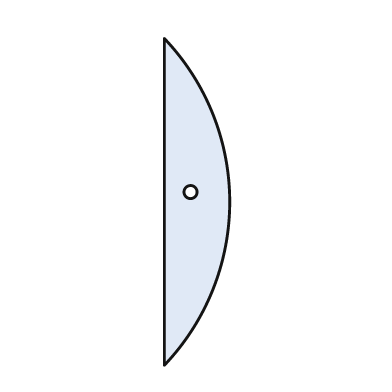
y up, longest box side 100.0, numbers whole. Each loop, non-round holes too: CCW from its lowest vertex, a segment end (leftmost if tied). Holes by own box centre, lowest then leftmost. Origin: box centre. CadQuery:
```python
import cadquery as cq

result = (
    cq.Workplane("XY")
    .moveTo(-10.0, -50.0)
    .threePointArc((10.0, 0.0), (-10.0, 50.0))
    .close()
    .moveTo(-2.0, 3.0)
    .circle(2.0)
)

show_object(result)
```